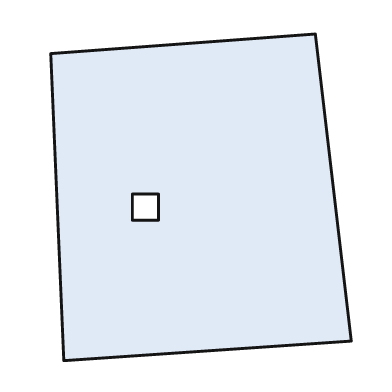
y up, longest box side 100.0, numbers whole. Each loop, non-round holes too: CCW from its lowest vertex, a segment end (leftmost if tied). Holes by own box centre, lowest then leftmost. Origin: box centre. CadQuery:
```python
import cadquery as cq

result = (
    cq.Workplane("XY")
    .moveTo(-42.0, -50.0)
    .lineTo(46.0, -44.0)
    .lineTo(35.0, 50.0)
    .lineTo(-46.0, 44.0)
    .close()
    .moveTo(-21.0, -7.0)
    .lineTo(-13.0, -7.0)
    .lineTo(-13.0, 1.0)
    .lineTo(-21.0, 1.0)
    .close()
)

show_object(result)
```